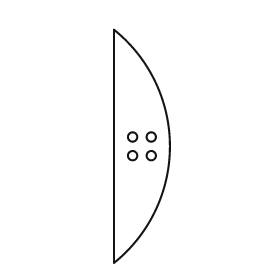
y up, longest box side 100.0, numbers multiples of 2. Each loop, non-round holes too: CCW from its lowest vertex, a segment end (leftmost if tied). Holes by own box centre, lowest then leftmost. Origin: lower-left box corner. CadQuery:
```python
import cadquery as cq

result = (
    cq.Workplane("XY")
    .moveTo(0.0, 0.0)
    .threePointArc((24.0, 50.0), (0.0, 100.0))
    .close()
    .moveTo(8.0, 46.0)
    .circle(2.0)
    .moveTo(16.0, 46.0)
    .circle(2.0)
    .moveTo(8.0, 54.0)
    .circle(2.0)
    .moveTo(16.0, 54.0)
    .circle(2.0)
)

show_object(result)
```